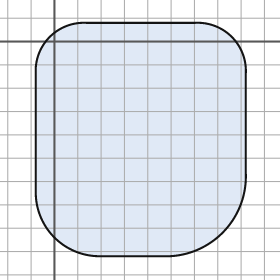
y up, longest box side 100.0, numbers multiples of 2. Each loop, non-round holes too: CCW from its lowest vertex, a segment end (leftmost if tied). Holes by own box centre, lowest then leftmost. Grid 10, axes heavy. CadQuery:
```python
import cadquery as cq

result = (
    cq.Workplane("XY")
    .moveTo(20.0, -92.0)
    .lineTo(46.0, -92.0)
    .threePointArc((72.0, -82.0), (82.0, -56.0))
    .lineTo(82.0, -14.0)
    .threePointArc((76.0, 2.0), (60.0, 8.0))
    .lineTo(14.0, 8.0)
    .threePointArc((-2.0, 2.0), (-8.0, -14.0))
    .lineTo(-8.0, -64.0)
    .threePointArc((0.0, -84.0), (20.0, -92.0))
    .close()
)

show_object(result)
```